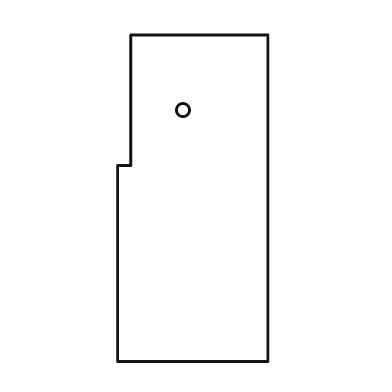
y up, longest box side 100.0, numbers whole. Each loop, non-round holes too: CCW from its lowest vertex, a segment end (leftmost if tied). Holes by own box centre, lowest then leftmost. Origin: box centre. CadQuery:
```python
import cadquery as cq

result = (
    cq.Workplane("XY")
    .moveTo(-23.0, -50.0)
    .lineTo(23.0, -50.0)
    .lineTo(23.0, 50.0)
    .lineTo(-19.0, 50.0)
    .lineTo(-19.0, 10.0)
    .lineTo(-23.0, 10.0)
    .close()
    .moveTo(-3.0, 27.0)
    .circle(2.0)
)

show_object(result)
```